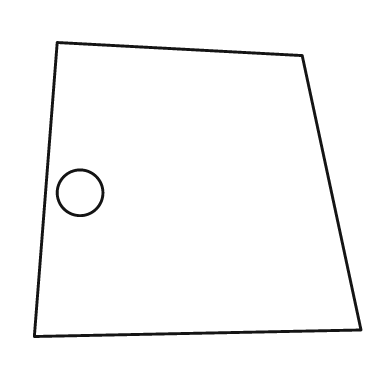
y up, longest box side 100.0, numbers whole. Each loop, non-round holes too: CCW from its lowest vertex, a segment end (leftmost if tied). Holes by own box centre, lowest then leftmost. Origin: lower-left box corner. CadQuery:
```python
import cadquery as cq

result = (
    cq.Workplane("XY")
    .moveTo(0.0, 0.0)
    .lineTo(100.0, 2.0)
    .lineTo(82.0, 86.0)
    .lineTo(7.0, 90.0)
    .close()
    .moveTo(14.0, 44.0)
    .circle(7.0)
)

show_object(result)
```